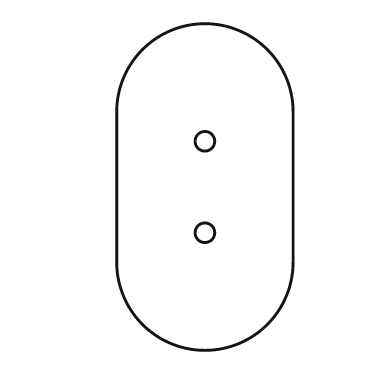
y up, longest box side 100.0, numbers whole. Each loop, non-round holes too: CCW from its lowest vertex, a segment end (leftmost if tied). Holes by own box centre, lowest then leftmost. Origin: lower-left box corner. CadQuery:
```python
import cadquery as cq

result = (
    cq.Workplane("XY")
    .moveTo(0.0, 27.0)
    .threePointArc((27.0, 0.0), (54.0, 27.0))
    .lineTo(54.0, 73.0)
    .threePointArc((27.0, 100.0), (0.0, 73.0))
    .close()
    .moveTo(27.0, 36.0)
    .circle(3.0)
    .moveTo(27.0, 64.0)
    .circle(3.0)
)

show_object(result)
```